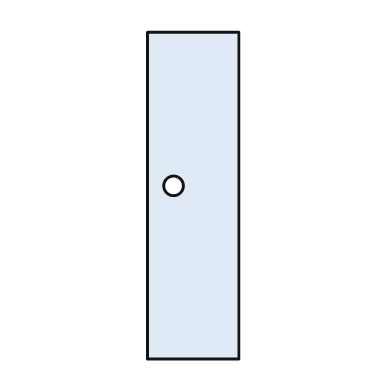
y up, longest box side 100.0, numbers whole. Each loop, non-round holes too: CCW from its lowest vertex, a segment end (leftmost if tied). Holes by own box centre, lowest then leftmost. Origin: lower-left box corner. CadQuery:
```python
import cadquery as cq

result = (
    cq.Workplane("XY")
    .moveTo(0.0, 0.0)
    .lineTo(28.0, 0.0)
    .lineTo(28.0, 100.0)
    .lineTo(0.0, 100.0)
    .close()
    .moveTo(8.0, 53.0)
    .circle(3.0)
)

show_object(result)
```